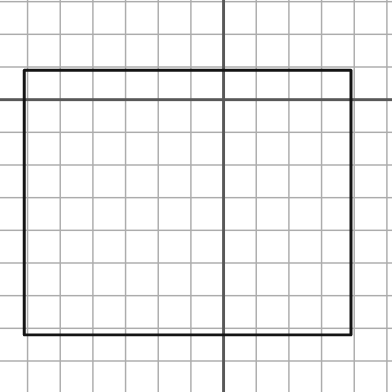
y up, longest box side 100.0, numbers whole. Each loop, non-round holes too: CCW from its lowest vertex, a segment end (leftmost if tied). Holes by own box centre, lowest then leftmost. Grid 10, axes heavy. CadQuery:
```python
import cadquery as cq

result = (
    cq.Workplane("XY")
    .moveTo(-61.0, -72.0)
    .lineTo(39.0, -72.0)
    .lineTo(39.0, 9.0)
    .lineTo(-61.0, 9.0)
    .close()
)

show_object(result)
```